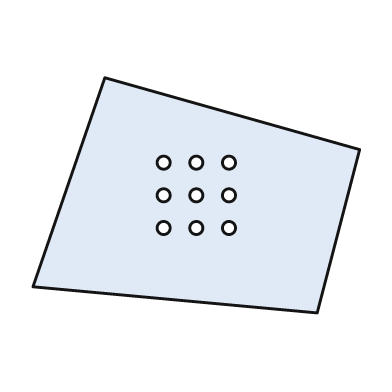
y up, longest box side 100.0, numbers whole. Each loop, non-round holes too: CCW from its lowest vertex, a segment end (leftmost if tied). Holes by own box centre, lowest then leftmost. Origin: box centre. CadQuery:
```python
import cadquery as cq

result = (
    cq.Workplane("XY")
    .moveTo(37.0, -36.0)
    .lineTo(50.0, 14.0)
    .lineTo(-28.0, 36.0)
    .lineTo(-50.0, -28.0)
    .close()
    .moveTo(-10.0, -10.0)
    .circle(2.0)
    .moveTo(0.0, -10.0)
    .circle(2.0)
    .moveTo(10.0, -10.0)
    .circle(2.0)
    .moveTo(-10.0, 0.0)
    .circle(2.0)
    .moveTo(0.0, 0.0)
    .circle(2.0)
    .moveTo(10.0, 0.0)
    .circle(2.0)
    .moveTo(-10.0, 10.0)
    .circle(2.0)
    .moveTo(0.0, 10.0)
    .circle(2.0)
    .moveTo(10.0, 10.0)
    .circle(2.0)
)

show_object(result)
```